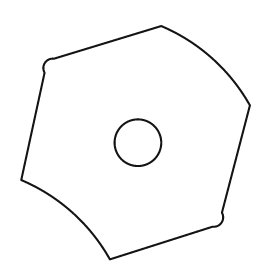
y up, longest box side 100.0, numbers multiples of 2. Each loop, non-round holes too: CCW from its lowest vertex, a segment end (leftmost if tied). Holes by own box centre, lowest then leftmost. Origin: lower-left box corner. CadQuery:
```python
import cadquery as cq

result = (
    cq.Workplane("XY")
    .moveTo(38.0, 0.0)
    .lineTo(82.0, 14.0)
    .threePointArc((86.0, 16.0), (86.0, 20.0))
    .lineTo(98.0, 66.0)
    .threePointArc((82.0, 86.0), (60.0, 100.0))
    .lineTo(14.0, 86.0)
    .threePointArc((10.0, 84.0), (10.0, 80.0))
    .lineTo(0.0, 34.0)
    .threePointArc((22.0, 20.0), (38.0, 0.0))
    .close()
    .moveTo(50.0, 50.0)
    .circle(10.0)
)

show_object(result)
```